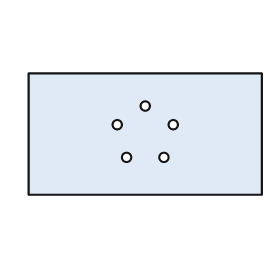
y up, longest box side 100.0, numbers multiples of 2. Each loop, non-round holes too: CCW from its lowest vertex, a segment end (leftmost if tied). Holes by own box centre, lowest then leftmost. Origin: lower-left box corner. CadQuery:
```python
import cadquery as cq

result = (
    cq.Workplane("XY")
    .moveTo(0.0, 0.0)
    .lineTo(100.0, 0.0)
    .lineTo(100.0, 52.0)
    .lineTo(0.0, 52.0)
    .close()
    .moveTo(42.0, 16.0)
    .circle(2.0)
    .moveTo(58.0, 16.0)
    .circle(2.0)
    .moveTo(38.0, 30.0)
    .circle(2.0)
    .moveTo(62.0, 30.0)
    .circle(2.0)
    .moveTo(50.0, 38.0)
    .circle(2.0)
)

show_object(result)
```